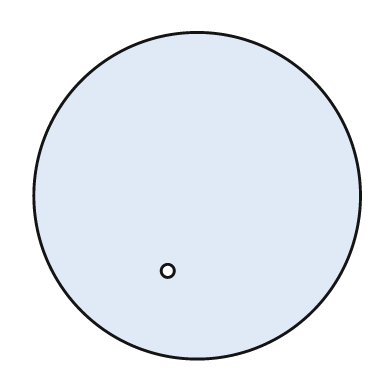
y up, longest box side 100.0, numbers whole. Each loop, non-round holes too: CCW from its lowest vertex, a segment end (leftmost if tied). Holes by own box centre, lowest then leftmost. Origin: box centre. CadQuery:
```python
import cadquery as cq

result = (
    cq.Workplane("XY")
    .moveTo(0.0, 0.0)
    .circle(50.0)
    .moveTo(-9.0, -23.0)
    .circle(2.0)
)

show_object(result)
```